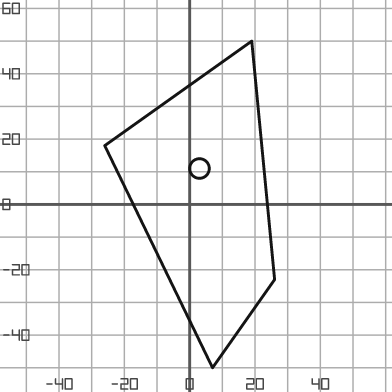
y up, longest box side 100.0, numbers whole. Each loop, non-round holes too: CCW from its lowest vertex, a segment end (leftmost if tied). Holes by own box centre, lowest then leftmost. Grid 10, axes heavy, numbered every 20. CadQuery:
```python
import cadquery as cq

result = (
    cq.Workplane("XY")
    .moveTo(7.0, -50.0)
    .lineTo(26.0, -23.0)
    .lineTo(19.0, 50.0)
    .lineTo(-26.0, 18.0)
    .close()
    .moveTo(3.0, 11.0)
    .circle(3.0)
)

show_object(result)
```